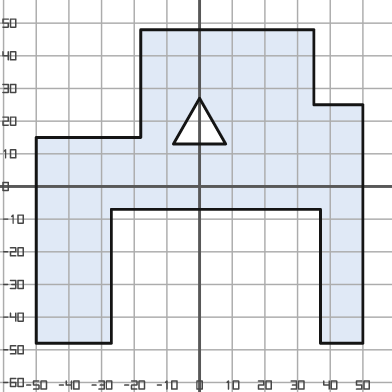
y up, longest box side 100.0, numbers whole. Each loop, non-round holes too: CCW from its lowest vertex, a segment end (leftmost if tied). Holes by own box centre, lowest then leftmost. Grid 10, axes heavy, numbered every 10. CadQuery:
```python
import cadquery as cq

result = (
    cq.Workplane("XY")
    .moveTo(-50.0, -48.0)
    .lineTo(-27.0, -48.0)
    .lineTo(-27.0, -7.0)
    .lineTo(37.0, -7.0)
    .lineTo(37.0, -48.0)
    .lineTo(50.0, -48.0)
    .lineTo(50.0, 25.0)
    .lineTo(35.0, 25.0)
    .lineTo(35.0, 48.0)
    .lineTo(-18.0, 48.0)
    .lineTo(-18.0, 15.0)
    .lineTo(-50.0, 15.0)
    .close()
    .moveTo(-8.0, 13.0)
    .lineTo(8.0, 13.0)
    .lineTo(0.0, 27.0)
    .close()
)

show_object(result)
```